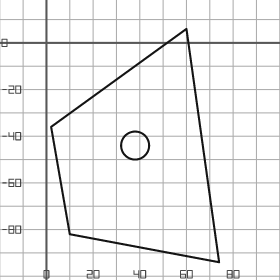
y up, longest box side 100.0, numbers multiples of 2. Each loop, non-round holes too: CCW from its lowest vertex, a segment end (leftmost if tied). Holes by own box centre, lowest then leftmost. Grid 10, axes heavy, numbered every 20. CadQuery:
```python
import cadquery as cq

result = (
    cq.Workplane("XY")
    .moveTo(74.0, -94.0)
    .lineTo(60.0, 6.0)
    .lineTo(2.0, -36.0)
    .lineTo(10.0, -82.0)
    .close()
    .moveTo(38.0, -44.0)
    .circle(6.0)
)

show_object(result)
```